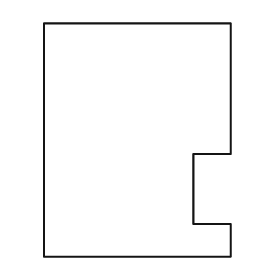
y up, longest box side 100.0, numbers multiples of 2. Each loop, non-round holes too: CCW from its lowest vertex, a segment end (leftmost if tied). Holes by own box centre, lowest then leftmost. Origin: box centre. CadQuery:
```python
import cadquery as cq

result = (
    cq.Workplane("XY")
    .moveTo(-40.0, -50.0)
    .lineTo(40.0, -50.0)
    .lineTo(40.0, -36.0)
    .lineTo(24.0, -36.0)
    .lineTo(24.0, -6.0)
    .lineTo(40.0, -6.0)
    .lineTo(40.0, 50.0)
    .lineTo(-40.0, 50.0)
    .close()
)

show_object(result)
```